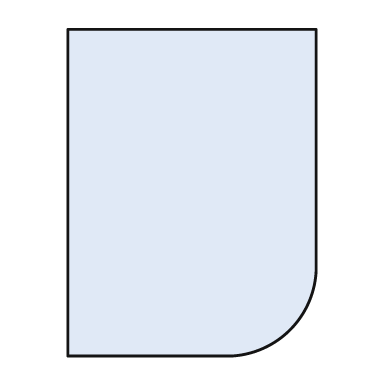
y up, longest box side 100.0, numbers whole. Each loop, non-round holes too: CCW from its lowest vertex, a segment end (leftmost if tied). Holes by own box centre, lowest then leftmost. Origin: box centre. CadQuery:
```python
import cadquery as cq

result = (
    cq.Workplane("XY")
    .moveTo(-38.0, -50.0)
    .lineTo(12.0, -50.0)
    .threePointArc((30.0, -42.0), (38.0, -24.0))
    .lineTo(38.0, 50.0)
    .lineTo(-38.0, 50.0)
    .close()
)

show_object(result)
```